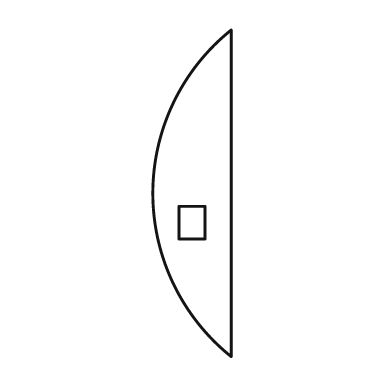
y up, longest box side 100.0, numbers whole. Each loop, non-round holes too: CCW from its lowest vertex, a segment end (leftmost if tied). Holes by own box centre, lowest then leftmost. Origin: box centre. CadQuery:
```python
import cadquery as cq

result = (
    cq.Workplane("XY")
    .moveTo(12.0, -50.0)
    .lineTo(12.0, 50.0)
    .threePointArc((-12.0, 0.0), (12.0, -50.0))
    .close()
    .moveTo(-4.0, -14.0)
    .lineTo(4.0, -14.0)
    .lineTo(4.0, -4.0)
    .lineTo(-4.0, -4.0)
    .close()
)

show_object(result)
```